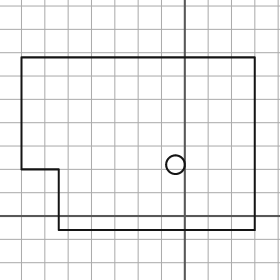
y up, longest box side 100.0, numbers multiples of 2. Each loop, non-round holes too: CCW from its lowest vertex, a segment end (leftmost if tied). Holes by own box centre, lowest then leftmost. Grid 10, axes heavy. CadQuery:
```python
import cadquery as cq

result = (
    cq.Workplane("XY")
    .moveTo(-54.0, -6.0)
    .lineTo(30.0, -6.0)
    .lineTo(30.0, 68.0)
    .lineTo(-70.0, 68.0)
    .lineTo(-70.0, 20.0)
    .lineTo(-54.0, 20.0)
    .close()
    .moveTo(-4.0, 22.0)
    .circle(4.0)
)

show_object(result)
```